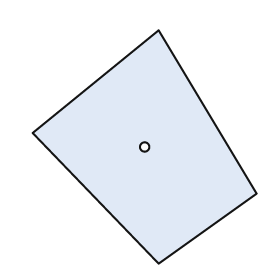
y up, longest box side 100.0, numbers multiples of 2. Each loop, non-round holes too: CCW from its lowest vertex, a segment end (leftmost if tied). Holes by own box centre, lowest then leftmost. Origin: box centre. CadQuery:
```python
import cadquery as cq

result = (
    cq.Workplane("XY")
    .moveTo(6.0, -50.0)
    .lineTo(48.0, -20.0)
    .lineTo(6.0, 50.0)
    .lineTo(-48.0, 6.0)
    .close()
    .moveTo(0.0, 0.0)
    .circle(2.0)
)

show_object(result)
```